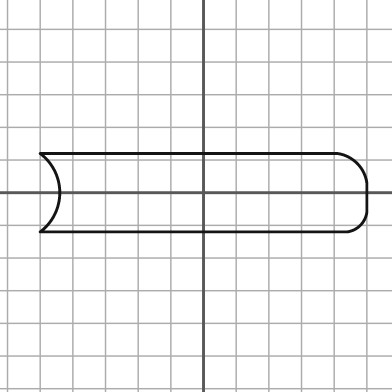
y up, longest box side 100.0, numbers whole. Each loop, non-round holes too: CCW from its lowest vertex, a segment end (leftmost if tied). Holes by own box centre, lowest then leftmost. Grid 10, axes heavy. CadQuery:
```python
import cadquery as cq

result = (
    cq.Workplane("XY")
    .moveTo(-50.0, -12.0)
    .lineTo(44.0, -12.0)
    .threePointArc((48.0, -10.0), (50.0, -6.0))
    .lineTo(50.0, 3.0)
    .threePointArc((47.0, 9.0), (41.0, 12.0))
    .lineTo(-50.0, 12.0)
    .threePointArc((-44.0, 0.0), (-50.0, -12.0))
    .close()
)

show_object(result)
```